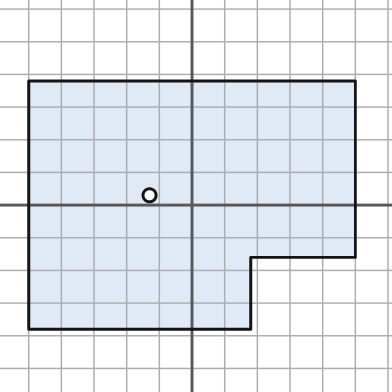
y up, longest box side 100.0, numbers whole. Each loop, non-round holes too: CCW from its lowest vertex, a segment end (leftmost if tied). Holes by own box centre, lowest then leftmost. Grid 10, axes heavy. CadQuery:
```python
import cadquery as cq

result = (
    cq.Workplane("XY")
    .moveTo(-50.0, -38.0)
    .lineTo(18.0, -38.0)
    .lineTo(18.0, -16.0)
    .lineTo(50.0, -16.0)
    .lineTo(50.0, 38.0)
    .lineTo(-50.0, 38.0)
    .close()
    .moveTo(-13.0, 3.0)
    .circle(2.0)
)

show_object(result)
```